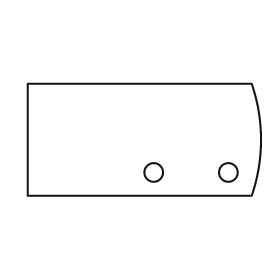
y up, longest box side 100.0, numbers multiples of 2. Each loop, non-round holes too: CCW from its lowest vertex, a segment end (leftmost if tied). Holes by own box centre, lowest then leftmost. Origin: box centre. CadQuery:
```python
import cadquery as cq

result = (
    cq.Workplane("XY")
    .moveTo(-50.0, -24.0)
    .lineTo(46.0, -24.0)
    .threePointArc((50.0, 0.0), (46.0, 24.0))
    .lineTo(-50.0, 24.0)
    .close()
    .moveTo(4.0, -14.0)
    .circle(4.0)
    .moveTo(36.0, -14.0)
    .circle(4.0)
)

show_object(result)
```